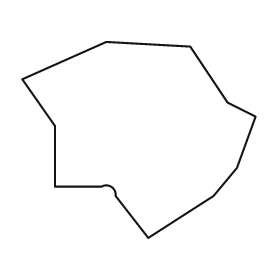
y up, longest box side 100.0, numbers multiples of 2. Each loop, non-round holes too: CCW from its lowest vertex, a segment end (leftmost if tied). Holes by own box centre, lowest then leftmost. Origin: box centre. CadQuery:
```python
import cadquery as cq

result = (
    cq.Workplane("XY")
    .moveTo(4.0, -42.0)
    .lineTo(32.0, -24.0)
    .lineTo(42.0, -12.0)
    .lineTo(50.0, 10.0)
    .lineTo(38.0, 16.0)
    .lineTo(22.0, 40.0)
    .lineTo(-14.0, 42.0)
    .lineTo(-50.0, 26.0)
    .lineTo(-36.0, 6.0)
    .lineTo(-36.0, -20.0)
    .lineTo(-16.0, -20.0)
    .threePointArc((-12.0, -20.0), (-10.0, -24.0))
    .close()
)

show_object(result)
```